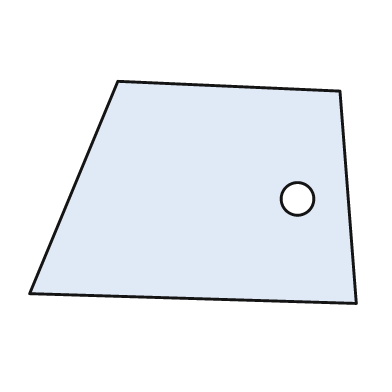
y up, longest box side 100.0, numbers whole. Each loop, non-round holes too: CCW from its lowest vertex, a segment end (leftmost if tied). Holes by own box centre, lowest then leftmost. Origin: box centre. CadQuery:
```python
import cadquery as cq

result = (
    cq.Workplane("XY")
    .moveTo(50.0, -34.0)
    .lineTo(45.0, 31.0)
    .lineTo(-23.0, 34.0)
    .lineTo(-50.0, -31.0)
    .close()
    .moveTo(32.0, -2.0)
    .circle(5.0)
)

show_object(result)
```